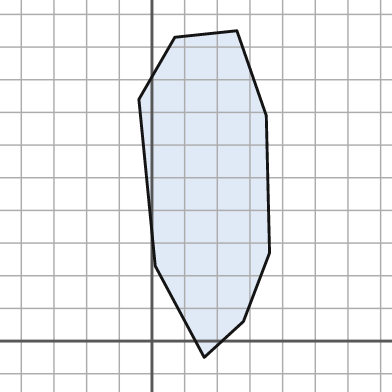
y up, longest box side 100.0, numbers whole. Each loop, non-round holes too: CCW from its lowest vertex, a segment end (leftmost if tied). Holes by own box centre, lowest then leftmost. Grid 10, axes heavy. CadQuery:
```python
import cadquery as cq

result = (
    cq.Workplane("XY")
    .moveTo(16.0, -5.0)
    .lineTo(28.0, 6.0)
    .lineTo(36.0, 27.0)
    .lineTo(35.0, 69.0)
    .lineTo(26.0, 95.0)
    .lineTo(7.0, 93.0)
    .lineTo(-4.0, 74.0)
    .lineTo(1.0, 23.0)
    .close()
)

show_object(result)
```